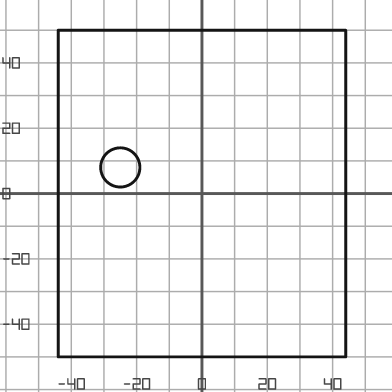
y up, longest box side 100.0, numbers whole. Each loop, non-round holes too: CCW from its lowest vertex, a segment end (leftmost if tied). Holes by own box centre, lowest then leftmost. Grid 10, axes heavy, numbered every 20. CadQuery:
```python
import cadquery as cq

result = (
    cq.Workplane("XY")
    .moveTo(-44.0, -50.0)
    .lineTo(44.0, -50.0)
    .lineTo(44.0, 50.0)
    .lineTo(-44.0, 50.0)
    .close()
    .moveTo(-25.0, 8.0)
    .circle(6.0)
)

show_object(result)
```